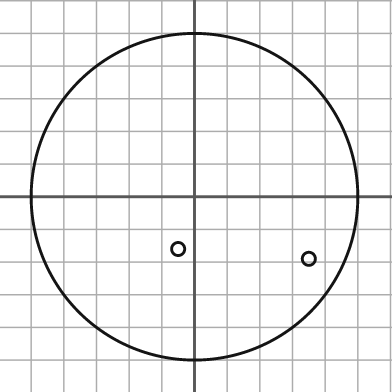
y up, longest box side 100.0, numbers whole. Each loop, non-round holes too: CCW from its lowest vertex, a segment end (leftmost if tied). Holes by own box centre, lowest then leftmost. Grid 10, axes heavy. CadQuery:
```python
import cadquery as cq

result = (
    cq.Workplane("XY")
    .moveTo(0.0, 0.0)
    .circle(50.0)
    .moveTo(35.0, -19.0)
    .circle(2.0)
    .moveTo(-5.0, -16.0)
    .circle(2.0)
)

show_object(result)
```